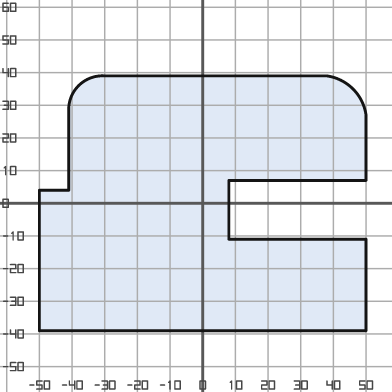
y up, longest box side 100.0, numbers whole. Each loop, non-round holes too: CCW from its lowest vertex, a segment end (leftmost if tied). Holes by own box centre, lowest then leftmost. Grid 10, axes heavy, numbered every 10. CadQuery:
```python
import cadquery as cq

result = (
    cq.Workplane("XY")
    .moveTo(-50.0, -39.0)
    .lineTo(50.0, -39.0)
    .lineTo(50.0, -11.0)
    .lineTo(8.0, -11.0)
    .lineTo(8.0, 7.0)
    .lineTo(50.0, 7.0)
    .lineTo(50.0, 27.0)
    .threePointArc((46.0, 35.0), (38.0, 39.0))
    .lineTo(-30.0, 39.0)
    .threePointArc((-38.0, 36.0), (-41.0, 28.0))
    .lineTo(-41.0, 4.0)
    .lineTo(-50.0, 4.0)
    .close()
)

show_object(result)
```